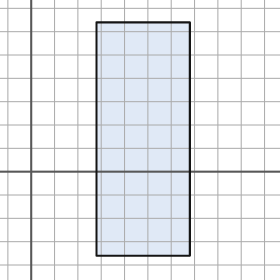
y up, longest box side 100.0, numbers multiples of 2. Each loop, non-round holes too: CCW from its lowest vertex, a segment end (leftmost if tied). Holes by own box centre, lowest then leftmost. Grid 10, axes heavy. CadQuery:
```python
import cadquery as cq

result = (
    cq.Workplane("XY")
    .moveTo(28.0, -36.0)
    .lineTo(68.0, -36.0)
    .lineTo(68.0, 64.0)
    .lineTo(28.0, 64.0)
    .close()
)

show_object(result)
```